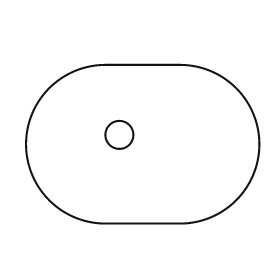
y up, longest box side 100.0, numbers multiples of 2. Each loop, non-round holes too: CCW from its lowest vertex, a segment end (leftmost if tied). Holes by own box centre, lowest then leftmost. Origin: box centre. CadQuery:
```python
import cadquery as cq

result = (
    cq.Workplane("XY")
    .moveTo(-16.0, -34.0)
    .lineTo(16.0, -34.0)
    .threePointArc((50.0, 0.0), (16.0, 34.0))
    .lineTo(-16.0, 34.0)
    .threePointArc((-50.0, 0.0), (-16.0, -34.0))
    .close()
    .moveTo(-10.0, 4.0)
    .circle(6.0)
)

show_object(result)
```